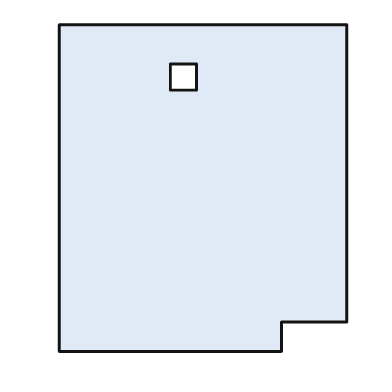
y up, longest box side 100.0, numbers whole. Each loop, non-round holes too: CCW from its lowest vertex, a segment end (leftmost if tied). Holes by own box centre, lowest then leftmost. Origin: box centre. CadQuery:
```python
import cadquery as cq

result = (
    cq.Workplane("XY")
    .moveTo(-44.0, -50.0)
    .lineTo(24.0, -50.0)
    .lineTo(24.0, -41.0)
    .lineTo(44.0, -41.0)
    .lineTo(44.0, 50.0)
    .lineTo(-44.0, 50.0)
    .close()
    .moveTo(-10.0, 30.0)
    .lineTo(-2.0, 30.0)
    .lineTo(-2.0, 38.0)
    .lineTo(-10.0, 38.0)
    .close()
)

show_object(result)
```